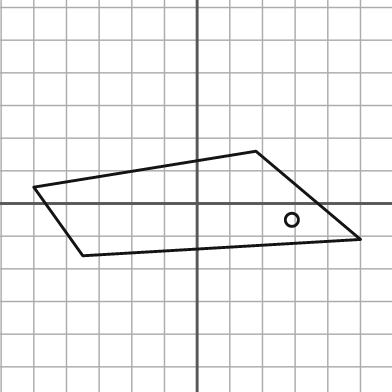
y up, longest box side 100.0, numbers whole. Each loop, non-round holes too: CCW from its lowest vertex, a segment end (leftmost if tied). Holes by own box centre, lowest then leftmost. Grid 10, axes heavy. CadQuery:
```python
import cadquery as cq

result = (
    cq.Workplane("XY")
    .moveTo(-35.0, -16.0)
    .lineTo(50.0, -11.0)
    .lineTo(18.0, 16.0)
    .lineTo(-50.0, 5.0)
    .close()
    .moveTo(29.0, -5.0)
    .circle(2.0)
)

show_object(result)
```